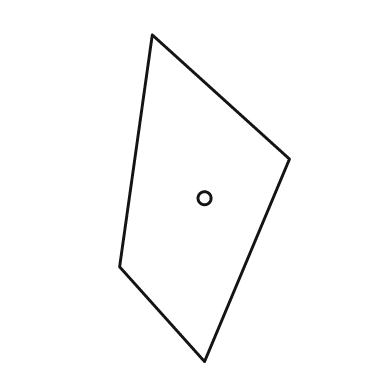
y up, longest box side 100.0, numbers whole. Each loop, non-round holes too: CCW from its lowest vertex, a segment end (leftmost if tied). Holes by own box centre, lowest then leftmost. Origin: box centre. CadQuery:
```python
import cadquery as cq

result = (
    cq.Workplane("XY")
    .moveTo(0.0, -50.0)
    .lineTo(26.0, 12.0)
    .lineTo(-16.0, 50.0)
    .lineTo(-26.0, -21.0)
    .close()
    .moveTo(0.0, 0.0)
    .circle(2.0)
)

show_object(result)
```